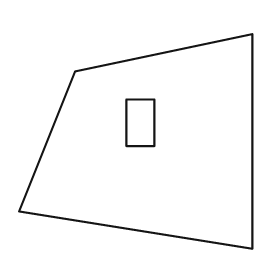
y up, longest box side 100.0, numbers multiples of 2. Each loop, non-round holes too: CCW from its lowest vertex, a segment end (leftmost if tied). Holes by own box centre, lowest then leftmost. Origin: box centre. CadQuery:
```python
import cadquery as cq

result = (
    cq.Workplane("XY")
    .moveTo(50.0, -46.0)
    .lineTo(50.0, 46.0)
    .lineTo(-26.0, 30.0)
    .lineTo(-50.0, -30.0)
    .close()
    .moveTo(-4.0, -2.0)
    .lineTo(8.0, -2.0)
    .lineTo(8.0, 18.0)
    .lineTo(-4.0, 18.0)
    .close()
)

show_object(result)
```